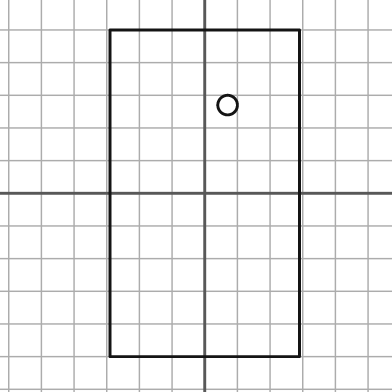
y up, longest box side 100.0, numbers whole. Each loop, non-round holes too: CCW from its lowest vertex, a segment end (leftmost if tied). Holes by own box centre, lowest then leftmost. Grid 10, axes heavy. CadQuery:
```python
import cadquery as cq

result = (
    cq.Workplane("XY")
    .moveTo(-29.0, -50.0)
    .lineTo(29.0, -50.0)
    .lineTo(29.0, 50.0)
    .lineTo(-29.0, 50.0)
    .close()
    .moveTo(7.0, 27.0)
    .circle(3.0)
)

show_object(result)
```